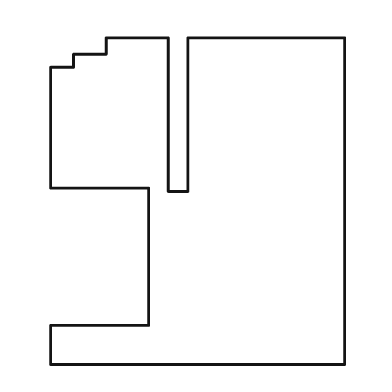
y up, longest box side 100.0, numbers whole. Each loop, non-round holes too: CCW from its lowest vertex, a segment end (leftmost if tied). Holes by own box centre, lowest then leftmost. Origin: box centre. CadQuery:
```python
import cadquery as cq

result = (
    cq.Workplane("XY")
    .moveTo(-45.0, -50.0)
    .lineTo(45.0, -50.0)
    .lineTo(45.0, 50.0)
    .lineTo(-3.0, 50.0)
    .lineTo(-3.0, 3.0)
    .lineTo(-9.0, 3.0)
    .lineTo(-9.0, 50.0)
    .lineTo(-28.0, 50.0)
    .lineTo(-28.0, 45.0)
    .lineTo(-38.0, 45.0)
    .lineTo(-38.0, 41.0)
    .lineTo(-45.0, 41.0)
    .lineTo(-45.0, 4.0)
    .lineTo(-15.0, 4.0)
    .lineTo(-15.0, -38.0)
    .lineTo(-45.0, -38.0)
    .close()
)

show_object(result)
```